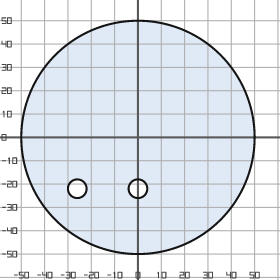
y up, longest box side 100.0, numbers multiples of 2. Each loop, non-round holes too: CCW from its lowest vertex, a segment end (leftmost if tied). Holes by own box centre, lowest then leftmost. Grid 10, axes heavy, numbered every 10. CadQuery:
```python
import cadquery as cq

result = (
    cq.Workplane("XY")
    .moveTo(0.0, 0.0)
    .circle(50.0)
    .moveTo(-26.0, -22.0)
    .circle(4.0)
    .moveTo(0.0, -22.0)
    .circle(4.0)
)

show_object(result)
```